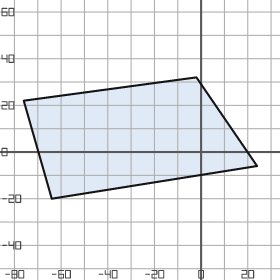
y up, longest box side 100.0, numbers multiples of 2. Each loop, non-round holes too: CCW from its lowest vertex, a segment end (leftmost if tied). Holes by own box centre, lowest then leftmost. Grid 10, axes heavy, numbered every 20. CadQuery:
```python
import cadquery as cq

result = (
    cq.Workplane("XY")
    .moveTo(-64.0, -20.0)
    .lineTo(24.0, -6.0)
    .lineTo(-2.0, 32.0)
    .lineTo(-76.0, 22.0)
    .close()
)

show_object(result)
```